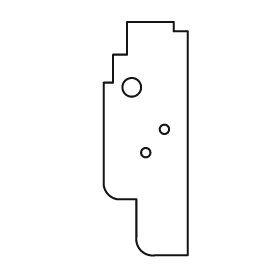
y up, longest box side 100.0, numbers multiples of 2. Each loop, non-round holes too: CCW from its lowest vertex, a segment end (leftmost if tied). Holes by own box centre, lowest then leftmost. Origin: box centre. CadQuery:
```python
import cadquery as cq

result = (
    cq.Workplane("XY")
    .moveTo(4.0, -50.0)
    .lineTo(18.0, -50.0)
    .lineTo(18.0, 46.0)
    .lineTo(12.0, 46.0)
    .lineTo(12.0, 50.0)
    .lineTo(-8.0, 50.0)
    .lineTo(-8.0, 36.0)
    .lineTo(-14.0, 36.0)
    .lineTo(-14.0, 24.0)
    .lineTo(-18.0, 24.0)
    .lineTo(-18.0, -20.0)
    .threePointArc((-16.0, -24.0), (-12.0, -26.0))
    .lineTo(-4.0, -26.0)
    .lineTo(-4.0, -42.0)
    .threePointArc((-2.0, -48.0), (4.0, -50.0))
    .close()
    .moveTo(0.0, -6.0)
    .circle(2.0)
    .moveTo(8.0, 4.0)
    .circle(2.0)
    .moveTo(-6.0, 22.0)
    .circle(4.0)
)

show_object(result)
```